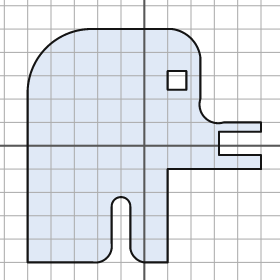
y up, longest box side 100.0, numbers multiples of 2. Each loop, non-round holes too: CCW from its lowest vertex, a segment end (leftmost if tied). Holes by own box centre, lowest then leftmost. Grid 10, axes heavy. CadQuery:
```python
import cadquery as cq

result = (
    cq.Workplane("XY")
    .moveTo(-50.0, -50.0)
    .lineTo(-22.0, -50.0)
    .threePointArc((-16.0, -48.0), (-14.0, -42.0))
    .lineTo(-14.0, -26.0)
    .threePointArc((-10.0, -22.0), (-6.0, -26.0))
    .lineTo(-6.0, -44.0)
    .threePointArc((-4.0, -48.0), (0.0, -50.0))
    .lineTo(10.0, -50.0)
    .lineTo(10.0, -10.0)
    .lineTo(50.0, -10.0)
    .lineTo(50.0, -4.0)
    .lineTo(32.0, -4.0)
    .lineTo(32.0, 6.0)
    .lineTo(50.0, 6.0)
    .lineTo(50.0, 10.0)
    .lineTo(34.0, 10.0)
    .threePointArc((26.0, 12.0), (24.0, 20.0))
    .lineTo(24.0, 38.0)
    .threePointArc((20.0, 46.0), (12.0, 50.0))
    .lineTo(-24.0, 50.0)
    .threePointArc((-42.0, 42.0), (-50.0, 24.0))
    .close()
    .moveTo(10.0, 24.0)
    .lineTo(18.0, 24.0)
    .lineTo(18.0, 32.0)
    .lineTo(10.0, 32.0)
    .close()
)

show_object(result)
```